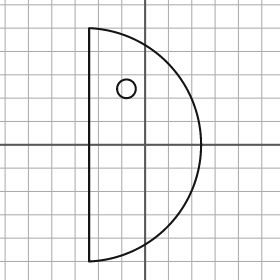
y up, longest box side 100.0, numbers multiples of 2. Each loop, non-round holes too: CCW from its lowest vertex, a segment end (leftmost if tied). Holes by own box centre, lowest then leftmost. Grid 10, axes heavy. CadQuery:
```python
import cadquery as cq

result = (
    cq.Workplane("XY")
    .moveTo(-24.0, -50.0)
    .threePointArc((24.0, 0.0), (-24.0, 50.0))
    .close()
    .moveTo(-8.0, 24.0)
    .circle(4.0)
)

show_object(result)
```